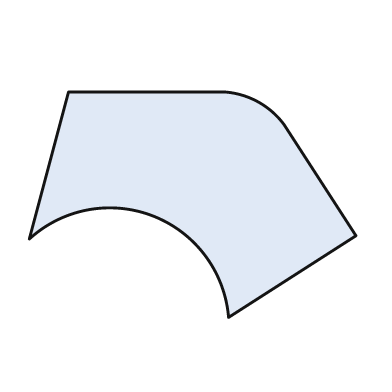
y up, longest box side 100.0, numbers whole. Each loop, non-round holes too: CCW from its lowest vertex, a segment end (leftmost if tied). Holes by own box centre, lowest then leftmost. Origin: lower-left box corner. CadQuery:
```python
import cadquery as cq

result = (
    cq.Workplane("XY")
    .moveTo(61.0, 0.0)
    .lineTo(100.0, 25.0)
    .lineTo(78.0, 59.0)
    .threePointArc((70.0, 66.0), (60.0, 69.0))
    .lineTo(12.0, 69.0)
    .lineTo(0.0, 24.0)
    .threePointArc((38.0, 31.0), (61.0, 0.0))
    .close()
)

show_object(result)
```